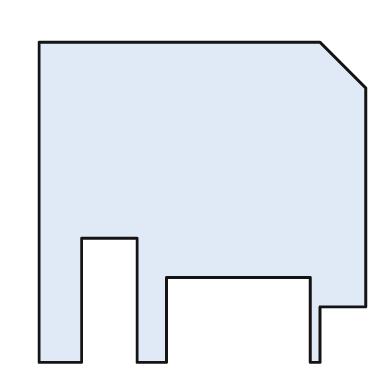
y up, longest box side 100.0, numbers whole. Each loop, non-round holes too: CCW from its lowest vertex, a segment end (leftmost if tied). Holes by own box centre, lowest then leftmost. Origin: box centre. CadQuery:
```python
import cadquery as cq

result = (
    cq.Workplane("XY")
    .moveTo(-50.0, -49.0)
    .lineTo(-37.0, -49.0)
    .lineTo(-37.0, -11.0)
    .lineTo(-20.0, -11.0)
    .lineTo(-20.0, -49.0)
    .lineTo(-11.0, -49.0)
    .lineTo(-11.0, -23.0)
    .lineTo(33.0, -23.0)
    .lineTo(33.0, -49.0)
    .lineTo(36.0, -49.0)
    .lineTo(36.0, -32.0)
    .lineTo(50.0, -32.0)
    .lineTo(50.0, 35.0)
    .lineTo(36.0, 49.0)
    .lineTo(-50.0, 49.0)
    .close()
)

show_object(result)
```